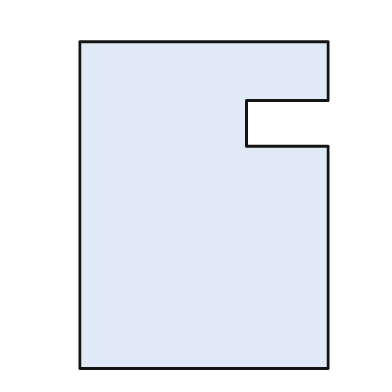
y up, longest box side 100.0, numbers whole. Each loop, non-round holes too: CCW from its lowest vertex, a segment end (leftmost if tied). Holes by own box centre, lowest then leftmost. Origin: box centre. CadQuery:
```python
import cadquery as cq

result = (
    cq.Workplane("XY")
    .moveTo(-38.0, -50.0)
    .lineTo(38.0, -50.0)
    .lineTo(38.0, 18.0)
    .lineTo(13.0, 18.0)
    .lineTo(13.0, 32.0)
    .lineTo(38.0, 32.0)
    .lineTo(38.0, 50.0)
    .lineTo(-38.0, 50.0)
    .close()
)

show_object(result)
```